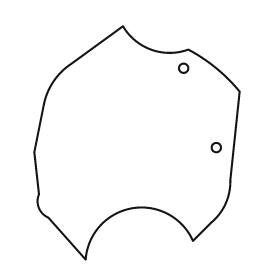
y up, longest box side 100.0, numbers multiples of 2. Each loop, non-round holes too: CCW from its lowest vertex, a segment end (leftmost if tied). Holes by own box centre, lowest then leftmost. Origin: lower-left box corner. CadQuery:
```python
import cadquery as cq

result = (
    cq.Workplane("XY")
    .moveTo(22.0, 0.0)
    .threePointArc((42.0, 22.0), (68.0, 8.0))
    .lineTo(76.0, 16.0)
    .threePointArc((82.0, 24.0), (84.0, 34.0))
    .lineTo(88.0, 72.0)
    .threePointArc((78.0, 82.0), (66.0, 90.0))
    .threePointArc((50.0, 90.0), (38.0, 100.0))
    .lineTo(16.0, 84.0)
    .threePointArc((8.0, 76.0), (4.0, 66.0))
    .lineTo(0.0, 46.0)
    .lineTo(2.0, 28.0)
    .threePointArc((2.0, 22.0), (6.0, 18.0))
    .close()
    .moveTo(78.0, 48.0)
    .circle(2.0)
    .moveTo(64.0, 82.0)
    .circle(2.0)
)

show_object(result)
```